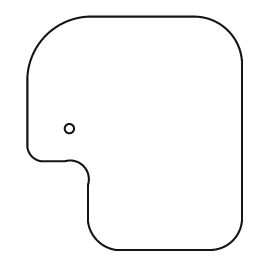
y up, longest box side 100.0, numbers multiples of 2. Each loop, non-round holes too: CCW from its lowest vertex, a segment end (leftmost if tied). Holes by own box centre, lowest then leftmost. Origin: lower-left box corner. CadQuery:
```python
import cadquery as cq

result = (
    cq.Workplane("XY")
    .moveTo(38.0, 0.0)
    .lineTo(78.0, 0.0)
    .threePointArc((88.0, 4.0), (92.0, 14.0))
    .lineTo(92.0, 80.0)
    .threePointArc((86.0, 94.0), (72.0, 100.0))
    .lineTo(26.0, 100.0)
    .threePointArc((8.0, 92.0), (0.0, 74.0))
    .lineTo(0.0, 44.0)
    .threePointArc((2.0, 40.0), (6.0, 38.0))
    .lineTo(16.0, 38.0)
    .threePointArc((24.0, 36.0), (26.0, 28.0))
    .lineTo(26.0, 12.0)
    .threePointArc((30.0, 4.0), (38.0, 0.0))
    .close()
    .moveTo(18.0, 52.0)
    .circle(2.0)
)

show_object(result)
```